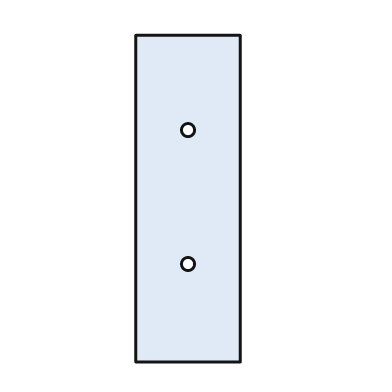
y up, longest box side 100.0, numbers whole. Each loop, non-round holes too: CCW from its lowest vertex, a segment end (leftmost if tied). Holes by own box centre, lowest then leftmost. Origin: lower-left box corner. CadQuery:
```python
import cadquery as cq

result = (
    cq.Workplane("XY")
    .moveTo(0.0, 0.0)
    .lineTo(32.0, 0.0)
    .lineTo(32.0, 100.0)
    .lineTo(0.0, 100.0)
    .close()
    .moveTo(16.0, 30.0)
    .circle(2.0)
    .moveTo(16.0, 71.0)
    .circle(2.0)
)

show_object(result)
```